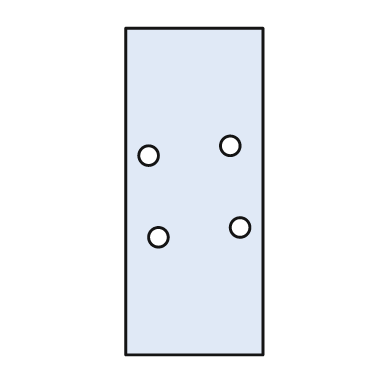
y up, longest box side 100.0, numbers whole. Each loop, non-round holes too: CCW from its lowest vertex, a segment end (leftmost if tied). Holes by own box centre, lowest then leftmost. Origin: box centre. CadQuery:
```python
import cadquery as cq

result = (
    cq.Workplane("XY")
    .moveTo(-21.0, -50.0)
    .lineTo(21.0, -50.0)
    .lineTo(21.0, 50.0)
    .lineTo(-21.0, 50.0)
    .close()
    .moveTo(-11.0, -14.0)
    .circle(3.0)
    .moveTo(14.0, -11.0)
    .circle(3.0)
    .moveTo(-14.0, 11.0)
    .circle(3.0)
    .moveTo(11.0, 14.0)
    .circle(3.0)
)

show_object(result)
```